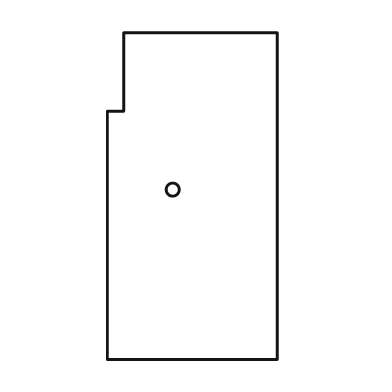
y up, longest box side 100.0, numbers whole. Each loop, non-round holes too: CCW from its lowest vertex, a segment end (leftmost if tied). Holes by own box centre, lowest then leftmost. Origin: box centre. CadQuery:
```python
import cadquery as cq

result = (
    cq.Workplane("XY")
    .moveTo(-26.0, -50.0)
    .lineTo(26.0, -50.0)
    .lineTo(26.0, 50.0)
    .lineTo(-21.0, 50.0)
    .lineTo(-21.0, 26.0)
    .lineTo(-26.0, 26.0)
    .close()
    .moveTo(-6.0, 2.0)
    .circle(2.0)
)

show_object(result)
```